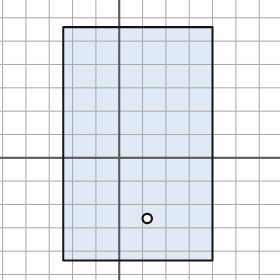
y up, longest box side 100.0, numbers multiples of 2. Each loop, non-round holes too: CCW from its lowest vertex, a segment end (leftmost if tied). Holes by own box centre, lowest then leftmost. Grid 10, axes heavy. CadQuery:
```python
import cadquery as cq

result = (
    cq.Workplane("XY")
    .moveTo(-24.0, -44.0)
    .lineTo(40.0, -44.0)
    .lineTo(40.0, 56.0)
    .lineTo(-24.0, 56.0)
    .close()
    .moveTo(12.0, -26.0)
    .circle(2.0)
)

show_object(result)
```